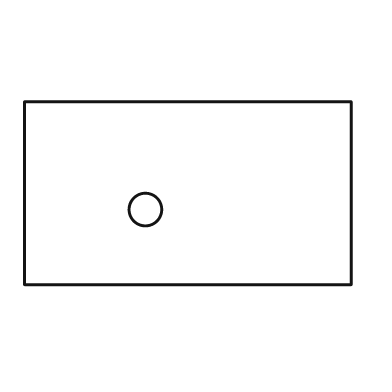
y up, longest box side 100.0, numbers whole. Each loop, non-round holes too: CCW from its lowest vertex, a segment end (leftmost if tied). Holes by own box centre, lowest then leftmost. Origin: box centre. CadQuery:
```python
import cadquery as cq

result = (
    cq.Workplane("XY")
    .moveTo(-50.0, -28.0)
    .lineTo(50.0, -28.0)
    .lineTo(50.0, 28.0)
    .lineTo(-50.0, 28.0)
    .close()
    .moveTo(-13.0, -5.0)
    .circle(5.0)
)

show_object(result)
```